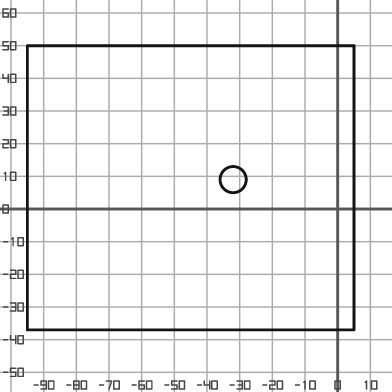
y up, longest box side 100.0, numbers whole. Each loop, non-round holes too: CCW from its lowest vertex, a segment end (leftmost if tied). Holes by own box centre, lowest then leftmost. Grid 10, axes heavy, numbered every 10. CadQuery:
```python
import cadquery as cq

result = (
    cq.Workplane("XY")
    .moveTo(-95.0, -37.0)
    .lineTo(5.0, -37.0)
    .lineTo(5.0, 50.0)
    .lineTo(-95.0, 50.0)
    .close()
    .moveTo(-32.0, 9.0)
    .circle(4.0)
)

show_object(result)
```